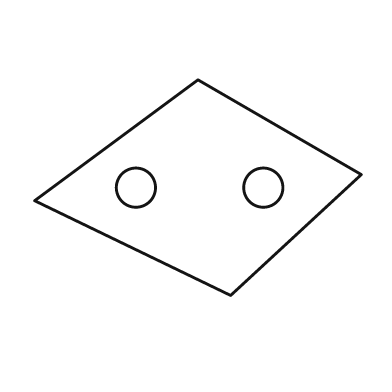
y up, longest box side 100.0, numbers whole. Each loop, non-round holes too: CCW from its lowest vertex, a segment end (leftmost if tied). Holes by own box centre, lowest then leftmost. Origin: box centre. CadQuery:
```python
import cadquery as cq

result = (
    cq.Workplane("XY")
    .moveTo(10.0, -33.0)
    .lineTo(50.0, 4.0)
    .lineTo(0.0, 33.0)
    .lineTo(-50.0, -4.0)
    .close()
    .moveTo(-19.0, 0.0)
    .circle(6.0)
    .moveTo(20.0, 0.0)
    .circle(6.0)
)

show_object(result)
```